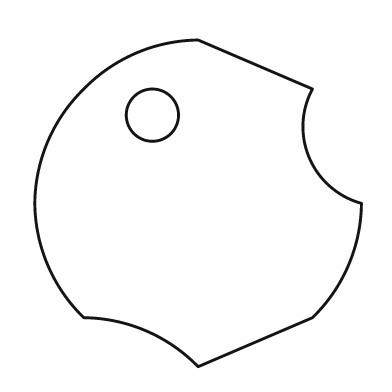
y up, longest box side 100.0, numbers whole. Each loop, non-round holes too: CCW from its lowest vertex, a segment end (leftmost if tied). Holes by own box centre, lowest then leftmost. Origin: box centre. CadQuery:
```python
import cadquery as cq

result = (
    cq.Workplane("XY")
    .moveTo(0.0, -50.0)
    .lineTo(35.0, -35.0)
    .threePointArc((46.0, -19.0), (50.0, 0.0))
    .threePointArc((34.0, 14.0), (35.0, 35.0))
    .lineTo(0.0, 50.0)
    .threePointArc((-19.0, 46.0), (-35.0, 35.0))
    .threePointArc((-46.0, 19.0), (-50.0, 0.0))
    .threePointArc((-46.0, -19.0), (-35.0, -35.0))
    .threePointArc((-16.0, -39.0), (0.0, -50.0))
    .close()
    .moveTo(-14.0, 27.0)
    .circle(8.0)
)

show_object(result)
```